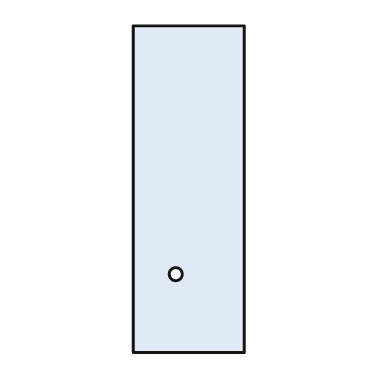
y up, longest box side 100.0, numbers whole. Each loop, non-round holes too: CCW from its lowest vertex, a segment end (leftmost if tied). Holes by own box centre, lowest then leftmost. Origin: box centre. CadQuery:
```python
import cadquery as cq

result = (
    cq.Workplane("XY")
    .moveTo(-17.0, -50.0)
    .lineTo(17.0, -50.0)
    .lineTo(17.0, 50.0)
    .lineTo(-17.0, 50.0)
    .close()
    .moveTo(-4.0, -26.0)
    .circle(2.0)
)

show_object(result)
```